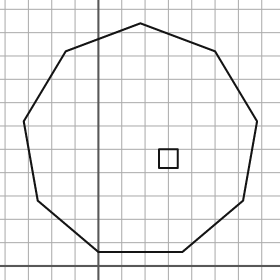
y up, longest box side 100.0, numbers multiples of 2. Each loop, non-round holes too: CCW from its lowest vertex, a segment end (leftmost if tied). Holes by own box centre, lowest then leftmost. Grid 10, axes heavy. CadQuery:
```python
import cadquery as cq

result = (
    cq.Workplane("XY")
    .moveTo(0.0, 6.0)
    .lineTo(36.0, 6.0)
    .lineTo(62.0, 28.0)
    .lineTo(68.0, 62.0)
    .lineTo(50.0, 92.0)
    .lineTo(18.0, 104.0)
    .lineTo(-14.0, 92.0)
    .lineTo(-32.0, 62.0)
    .lineTo(-26.0, 28.0)
    .close()
    .moveTo(26.0, 42.0)
    .lineTo(34.0, 42.0)
    .lineTo(34.0, 50.0)
    .lineTo(26.0, 50.0)
    .close()
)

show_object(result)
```